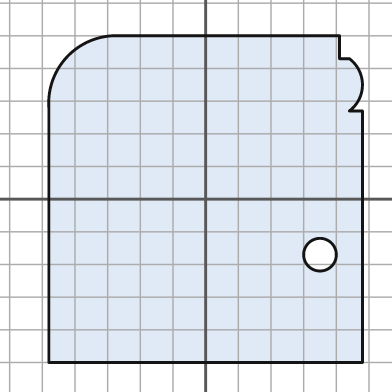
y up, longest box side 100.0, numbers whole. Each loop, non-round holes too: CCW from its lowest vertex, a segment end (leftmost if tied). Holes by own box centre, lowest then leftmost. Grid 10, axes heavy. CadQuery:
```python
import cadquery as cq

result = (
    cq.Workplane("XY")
    .moveTo(-48.0, -50.0)
    .lineTo(48.0, -50.0)
    .lineTo(48.0, 27.0)
    .lineTo(44.0, 27.0)
    .threePointArc((48.0, 35.0), (44.0, 43.0))
    .lineTo(41.0, 43.0)
    .lineTo(41.0, 50.0)
    .lineTo(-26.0, 50.0)
    .threePointArc((-42.0, 44.0), (-48.0, 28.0))
    .close()
    .moveTo(35.0, -17.0)
    .circle(5.0)
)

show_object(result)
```